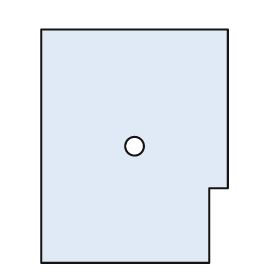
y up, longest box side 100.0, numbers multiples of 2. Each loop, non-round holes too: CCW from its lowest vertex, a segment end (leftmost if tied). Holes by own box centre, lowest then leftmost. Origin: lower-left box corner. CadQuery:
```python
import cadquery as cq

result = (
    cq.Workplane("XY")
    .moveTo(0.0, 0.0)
    .lineTo(72.0, 0.0)
    .lineTo(72.0, 32.0)
    .lineTo(80.0, 32.0)
    .lineTo(80.0, 100.0)
    .lineTo(0.0, 100.0)
    .close()
    .moveTo(40.0, 50.0)
    .circle(4.0)
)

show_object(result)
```